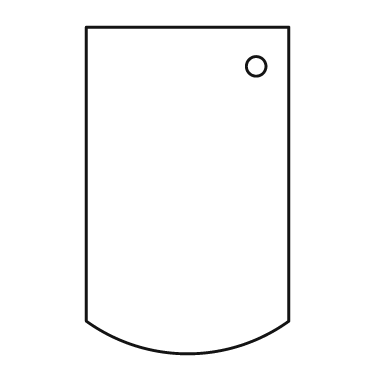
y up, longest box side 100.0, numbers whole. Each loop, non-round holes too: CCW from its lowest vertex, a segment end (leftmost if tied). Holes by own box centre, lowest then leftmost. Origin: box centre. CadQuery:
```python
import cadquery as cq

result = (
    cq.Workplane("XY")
    .moveTo(-31.0, -40.0)
    .threePointArc((0.0, -50.0), (31.0, -40.0))
    .lineTo(31.0, 50.0)
    .lineTo(-31.0, 50.0)
    .close()
    .moveTo(21.0, 38.0)
    .circle(3.0)
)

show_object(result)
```